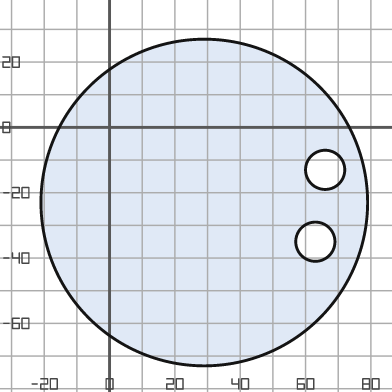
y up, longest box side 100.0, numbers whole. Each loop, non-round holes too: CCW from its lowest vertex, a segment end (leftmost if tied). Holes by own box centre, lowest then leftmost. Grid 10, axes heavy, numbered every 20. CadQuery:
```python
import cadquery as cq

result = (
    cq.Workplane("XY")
    .moveTo(29.0, -23.0)
    .circle(50.0)
    .moveTo(63.0, -35.0)
    .circle(6.0)
    .moveTo(66.0, -13.0)
    .circle(6.0)
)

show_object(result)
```